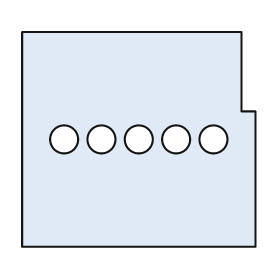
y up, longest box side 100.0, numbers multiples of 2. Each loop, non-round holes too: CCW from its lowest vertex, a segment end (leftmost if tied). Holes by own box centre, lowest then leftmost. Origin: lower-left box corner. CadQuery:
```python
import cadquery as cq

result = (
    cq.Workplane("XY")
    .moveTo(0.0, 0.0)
    .lineTo(100.0, 0.0)
    .lineTo(100.0, 58.0)
    .lineTo(94.0, 58.0)
    .lineTo(94.0, 92.0)
    .lineTo(0.0, 92.0)
    .close()
    .moveTo(18.0, 46.0)
    .circle(6.0)
    .moveTo(34.0, 46.0)
    .circle(6.0)
    .moveTo(50.0, 46.0)
    .circle(6.0)
    .moveTo(66.0, 46.0)
    .circle(6.0)
    .moveTo(82.0, 46.0)
    .circle(6.0)
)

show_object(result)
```